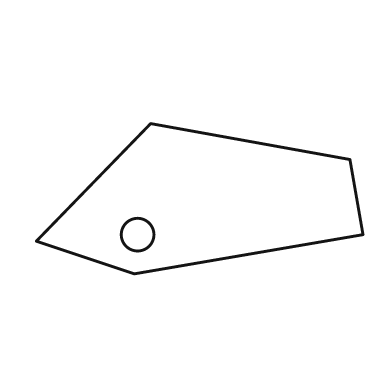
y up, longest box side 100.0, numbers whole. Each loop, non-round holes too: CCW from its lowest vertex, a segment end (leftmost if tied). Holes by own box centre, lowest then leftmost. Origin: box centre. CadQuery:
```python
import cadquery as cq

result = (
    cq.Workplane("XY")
    .moveTo(-20.0, -23.0)
    .lineTo(50.0, -11.0)
    .lineTo(46.0, 12.0)
    .lineTo(-15.0, 23.0)
    .lineTo(-50.0, -13.0)
    .close()
    .moveTo(-19.0, -11.0)
    .circle(5.0)
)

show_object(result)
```